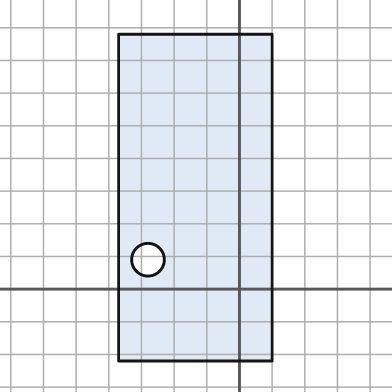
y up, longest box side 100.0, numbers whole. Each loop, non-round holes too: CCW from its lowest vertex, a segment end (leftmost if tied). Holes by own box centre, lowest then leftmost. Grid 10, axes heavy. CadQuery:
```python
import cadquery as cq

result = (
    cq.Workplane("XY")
    .moveTo(-37.0, -22.0)
    .lineTo(10.0, -22.0)
    .lineTo(10.0, 78.0)
    .lineTo(-37.0, 78.0)
    .close()
    .moveTo(-28.0, 9.0)
    .circle(5.0)
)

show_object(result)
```